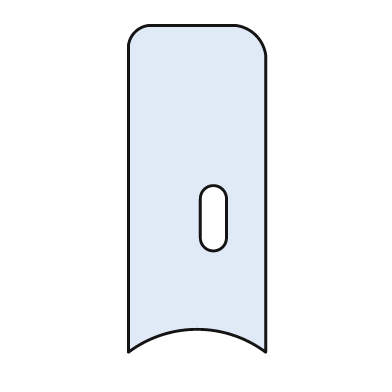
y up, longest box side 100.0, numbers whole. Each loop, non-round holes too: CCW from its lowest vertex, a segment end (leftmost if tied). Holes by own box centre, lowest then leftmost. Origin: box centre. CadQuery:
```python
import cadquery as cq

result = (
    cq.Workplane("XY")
    .moveTo(-21.0, -50.0)
    .threePointArc((0.0, -43.0), (21.0, -50.0))
    .lineTo(21.0, 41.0)
    .threePointArc((18.0, 47.0), (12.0, 50.0))
    .lineTo(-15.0, 50.0)
    .threePointArc((-19.0, 48.0), (-21.0, 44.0))
    .close()
    .moveTo(1.0, -15.0)
    .threePointArc((5.0, -19.0), (9.0, -15.0))
    .lineTo(9.0, -3.0)
    .threePointArc((5.0, 1.0), (1.0, -3.0))
    .close()
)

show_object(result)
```